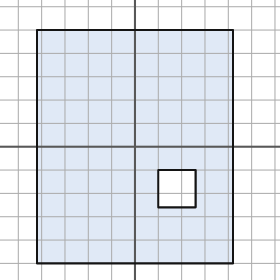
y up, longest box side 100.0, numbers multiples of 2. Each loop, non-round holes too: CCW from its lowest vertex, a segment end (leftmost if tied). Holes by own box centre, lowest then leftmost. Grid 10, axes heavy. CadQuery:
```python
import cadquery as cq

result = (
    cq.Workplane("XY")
    .moveTo(-42.0, -50.0)
    .lineTo(42.0, -50.0)
    .lineTo(42.0, 50.0)
    .lineTo(-42.0, 50.0)
    .close()
    .moveTo(10.0, -26.0)
    .lineTo(26.0, -26.0)
    .lineTo(26.0, -10.0)
    .lineTo(10.0, -10.0)
    .close()
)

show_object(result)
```